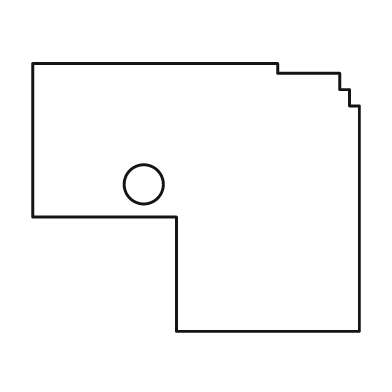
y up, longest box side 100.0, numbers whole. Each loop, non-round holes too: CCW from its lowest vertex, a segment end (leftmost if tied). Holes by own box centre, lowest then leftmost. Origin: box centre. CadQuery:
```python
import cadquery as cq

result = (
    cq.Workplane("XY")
    .moveTo(-6.0, -41.0)
    .lineTo(50.0, -41.0)
    .lineTo(50.0, 28.0)
    .lineTo(47.0, 28.0)
    .lineTo(47.0, 33.0)
    .lineTo(44.0, 33.0)
    .lineTo(44.0, 38.0)
    .lineTo(25.0, 38.0)
    .lineTo(25.0, 41.0)
    .lineTo(-50.0, 41.0)
    .lineTo(-50.0, -6.0)
    .lineTo(-6.0, -6.0)
    .close()
    .moveTo(-16.0, 4.0)
    .circle(6.0)
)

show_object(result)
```